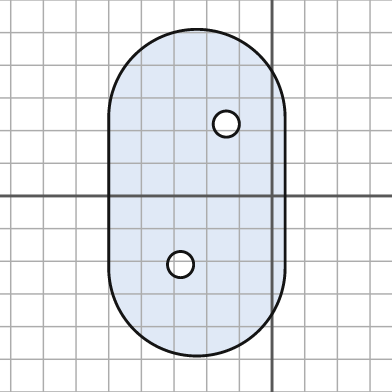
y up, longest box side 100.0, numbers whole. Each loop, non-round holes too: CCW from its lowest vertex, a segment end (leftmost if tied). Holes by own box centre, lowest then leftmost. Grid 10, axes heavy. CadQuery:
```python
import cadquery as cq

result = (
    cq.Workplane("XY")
    .moveTo(-50.0, -22.0)
    .threePointArc((-23.0, -49.0), (4.0, -22.0))
    .lineTo(4.0, 24.0)
    .threePointArc((-23.0, 51.0), (-50.0, 24.0))
    .close()
    .moveTo(-28.0, -21.0)
    .circle(4.0)
    .moveTo(-14.0, 22.0)
    .circle(4.0)
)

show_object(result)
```